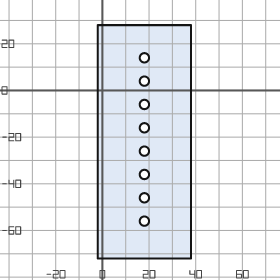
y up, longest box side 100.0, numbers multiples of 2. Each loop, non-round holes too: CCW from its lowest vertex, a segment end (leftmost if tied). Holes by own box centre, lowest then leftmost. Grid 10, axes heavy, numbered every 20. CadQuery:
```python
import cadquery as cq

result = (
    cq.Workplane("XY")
    .moveTo(-2.0, -72.0)
    .lineTo(38.0, -72.0)
    .lineTo(38.0, 28.0)
    .lineTo(-2.0, 28.0)
    .close()
    .moveTo(18.0, -56.0)
    .circle(2.0)
    .moveTo(18.0, -46.0)
    .circle(2.0)
    .moveTo(18.0, -36.0)
    .circle(2.0)
    .moveTo(18.0, -26.0)
    .circle(2.0)
    .moveTo(18.0, -16.0)
    .circle(2.0)
    .moveTo(18.0, -6.0)
    .circle(2.0)
    .moveTo(18.0, 4.0)
    .circle(2.0)
    .moveTo(18.0, 14.0)
    .circle(2.0)
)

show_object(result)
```